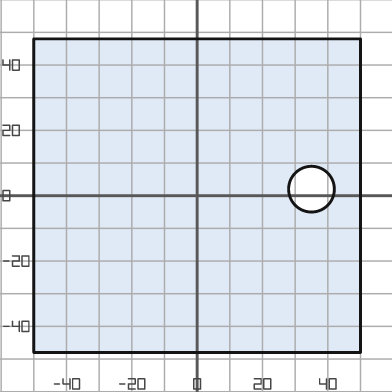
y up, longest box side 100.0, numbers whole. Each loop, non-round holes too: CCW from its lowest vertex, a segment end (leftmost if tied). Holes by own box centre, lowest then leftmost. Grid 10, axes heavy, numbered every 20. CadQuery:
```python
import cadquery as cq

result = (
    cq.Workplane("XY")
    .moveTo(-50.0, -48.0)
    .lineTo(50.0, -48.0)
    .lineTo(50.0, 48.0)
    .lineTo(-50.0, 48.0)
    .close()
    .moveTo(35.0, 2.0)
    .circle(7.0)
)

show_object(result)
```